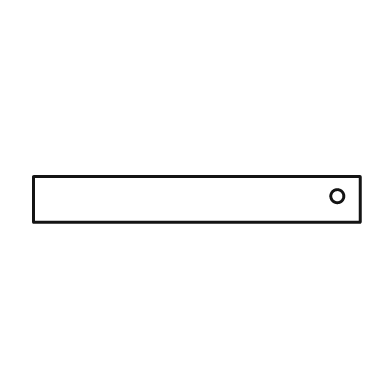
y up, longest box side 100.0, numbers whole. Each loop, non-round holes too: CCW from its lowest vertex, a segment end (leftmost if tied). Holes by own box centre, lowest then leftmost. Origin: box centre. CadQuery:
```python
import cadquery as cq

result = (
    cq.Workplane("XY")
    .moveTo(-50.0, -7.0)
    .lineTo(50.0, -7.0)
    .lineTo(50.0, 7.0)
    .lineTo(-50.0, 7.0)
    .close()
    .moveTo(43.0, 1.0)
    .circle(2.0)
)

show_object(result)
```